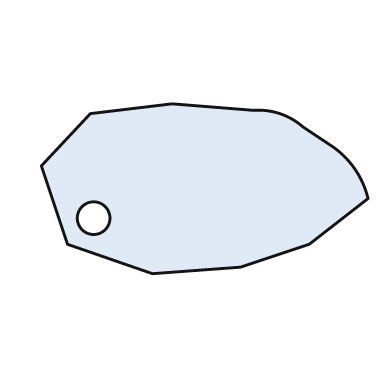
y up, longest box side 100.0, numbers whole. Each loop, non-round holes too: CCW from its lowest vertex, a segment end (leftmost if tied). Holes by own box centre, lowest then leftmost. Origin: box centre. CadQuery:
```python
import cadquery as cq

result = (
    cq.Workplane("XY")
    .moveTo(-16.0, -26.0)
    .lineTo(11.0, -24.0)
    .lineTo(32.0, -17.0)
    .lineTo(50.0, -3.0)
    .threePointArc((46.0, 6.0), (39.0, 13.0))
    .lineTo(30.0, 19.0)
    .threePointArc((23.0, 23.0), (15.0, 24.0))
    .lineTo(-10.0, 26.0)
    .lineTo(-35.0, 23.0)
    .lineTo(-50.0, 7.0)
    .lineTo(-42.0, -17.0)
    .close()
    .moveTo(-34.0, -9.0)
    .circle(5.0)
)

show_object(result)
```